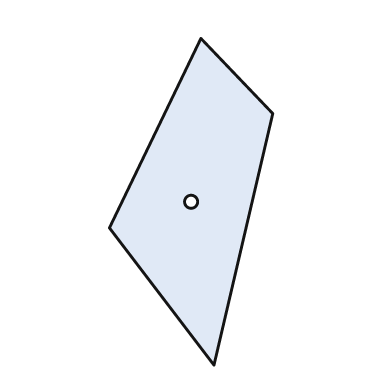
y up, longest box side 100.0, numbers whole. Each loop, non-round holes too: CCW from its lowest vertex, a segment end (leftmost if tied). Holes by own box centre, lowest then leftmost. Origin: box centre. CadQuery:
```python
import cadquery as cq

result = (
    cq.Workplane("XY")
    .moveTo(7.0, -50.0)
    .lineTo(25.0, 27.0)
    .lineTo(3.0, 50.0)
    .lineTo(-25.0, -8.0)
    .close()
    .moveTo(0.0, 0.0)
    .circle(2.0)
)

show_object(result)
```